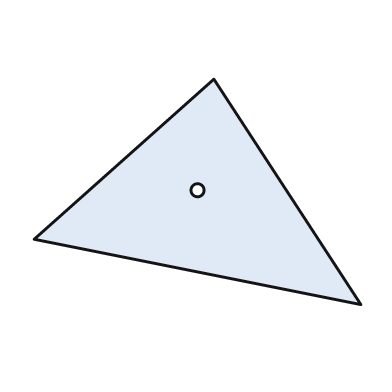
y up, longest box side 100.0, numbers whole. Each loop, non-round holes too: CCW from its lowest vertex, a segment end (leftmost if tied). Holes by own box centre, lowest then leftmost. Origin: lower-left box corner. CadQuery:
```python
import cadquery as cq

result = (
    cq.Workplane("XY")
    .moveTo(100.0, 0.0)
    .lineTo(55.0, 69.0)
    .lineTo(0.0, 20.0)
    .close()
    .moveTo(50.0, 35.0)
    .circle(2.0)
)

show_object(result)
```